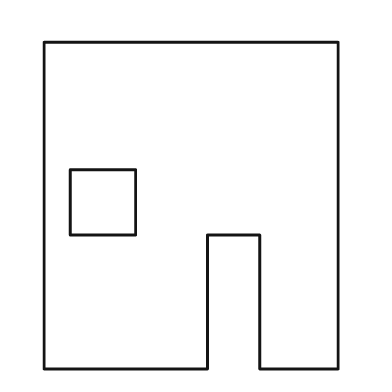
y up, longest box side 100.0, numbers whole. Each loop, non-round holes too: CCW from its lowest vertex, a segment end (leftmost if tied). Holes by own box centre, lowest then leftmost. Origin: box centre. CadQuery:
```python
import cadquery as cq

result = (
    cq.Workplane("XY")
    .moveTo(-45.0, -50.0)
    .lineTo(5.0, -50.0)
    .lineTo(5.0, -9.0)
    .lineTo(21.0, -9.0)
    .lineTo(21.0, -50.0)
    .lineTo(45.0, -50.0)
    .lineTo(45.0, 50.0)
    .lineTo(-45.0, 50.0)
    .close()
    .moveTo(-37.0, -9.0)
    .lineTo(-17.0, -9.0)
    .lineTo(-17.0, 11.0)
    .lineTo(-37.0, 11.0)
    .close()
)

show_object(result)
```